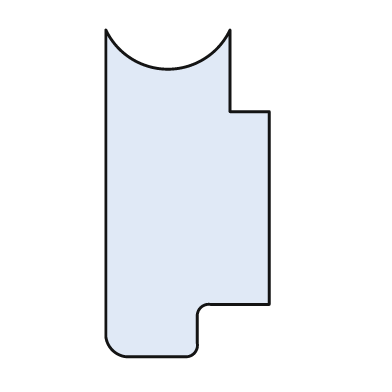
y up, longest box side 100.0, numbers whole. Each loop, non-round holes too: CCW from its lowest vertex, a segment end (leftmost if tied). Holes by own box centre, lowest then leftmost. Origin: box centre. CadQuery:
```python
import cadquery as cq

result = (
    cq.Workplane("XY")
    .moveTo(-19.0, -50.0)
    .lineTo(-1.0, -50.0)
    .threePointArc((2.0, -49.0), (3.0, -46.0))
    .lineTo(3.0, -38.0)
    .threePointArc((4.0, -35.0), (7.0, -34.0))
    .lineTo(25.0, -34.0)
    .lineTo(25.0, 25.0)
    .lineTo(13.0, 25.0)
    .lineTo(13.0, 50.0)
    .threePointArc((-6.0, 38.0), (-25.0, 50.0))
    .lineTo(-25.0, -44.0)
    .threePointArc((-23.0, -48.0), (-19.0, -50.0))
    .close()
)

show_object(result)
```